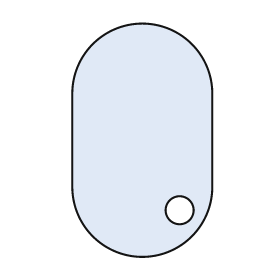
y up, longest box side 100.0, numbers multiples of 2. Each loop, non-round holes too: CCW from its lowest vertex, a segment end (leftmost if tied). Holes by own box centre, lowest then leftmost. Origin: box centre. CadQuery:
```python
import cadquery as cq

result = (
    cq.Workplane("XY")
    .moveTo(-30.0, -20.0)
    .threePointArc((0.0, -50.0), (30.0, -20.0))
    .lineTo(30.0, 20.0)
    .threePointArc((0.0, 50.0), (-30.0, 20.0))
    .close()
    .moveTo(16.0, -30.0)
    .circle(6.0)
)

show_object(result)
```